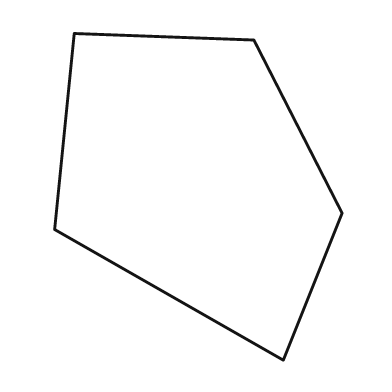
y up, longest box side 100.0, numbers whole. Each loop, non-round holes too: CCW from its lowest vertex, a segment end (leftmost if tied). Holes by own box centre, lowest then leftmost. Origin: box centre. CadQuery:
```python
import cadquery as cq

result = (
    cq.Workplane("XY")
    .moveTo(26.0, -50.0)
    .lineTo(44.0, -5.0)
    .lineTo(17.0, 48.0)
    .lineTo(-38.0, 50.0)
    .lineTo(-44.0, -10.0)
    .close()
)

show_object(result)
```